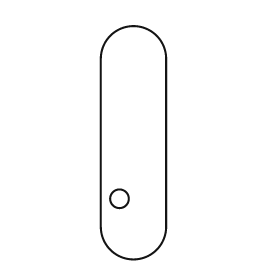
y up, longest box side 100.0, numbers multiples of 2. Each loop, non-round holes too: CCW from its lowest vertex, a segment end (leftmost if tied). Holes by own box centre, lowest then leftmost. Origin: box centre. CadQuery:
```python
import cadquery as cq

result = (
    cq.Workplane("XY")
    .moveTo(-14.0, -36.0)
    .threePointArc((0.0, -50.0), (14.0, -36.0))
    .lineTo(14.0, 36.0)
    .threePointArc((0.0, 50.0), (-14.0, 36.0))
    .close()
    .moveTo(-6.0, -24.0)
    .circle(4.0)
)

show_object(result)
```